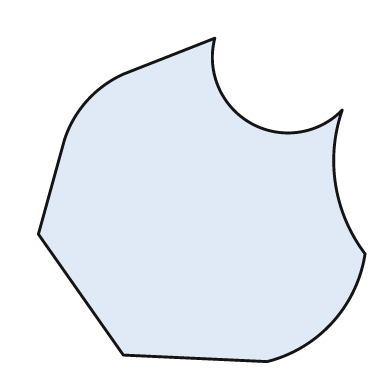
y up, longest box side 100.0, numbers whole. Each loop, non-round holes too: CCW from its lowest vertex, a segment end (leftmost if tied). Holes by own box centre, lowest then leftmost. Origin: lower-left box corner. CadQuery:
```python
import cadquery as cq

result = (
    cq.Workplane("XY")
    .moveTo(70.0, 0.0)
    .threePointArc((90.0, 12.0), (100.0, 33.0))
    .threePointArc((91.0, 54.0), (93.0, 77.0))
    .threePointArc((65.0, 73.0), (54.0, 99.0))
    .lineTo(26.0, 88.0)
    .threePointArc((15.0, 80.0), (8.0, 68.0))
    .lineTo(0.0, 39.0)
    .lineTo(26.0, 2.0)
    .close()
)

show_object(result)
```